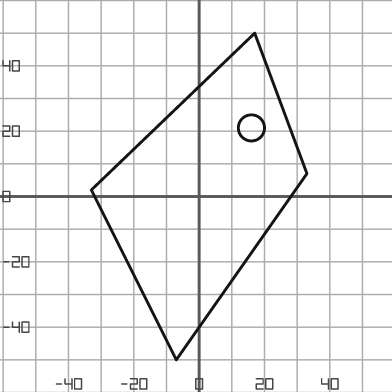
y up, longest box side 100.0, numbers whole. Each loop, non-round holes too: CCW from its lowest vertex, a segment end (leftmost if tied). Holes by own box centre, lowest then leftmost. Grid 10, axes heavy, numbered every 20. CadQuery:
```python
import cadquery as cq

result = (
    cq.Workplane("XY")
    .moveTo(-7.0, -50.0)
    .lineTo(33.0, 7.0)
    .lineTo(17.0, 50.0)
    .lineTo(-33.0, 2.0)
    .close()
    .moveTo(16.0, 21.0)
    .circle(4.0)
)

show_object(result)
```